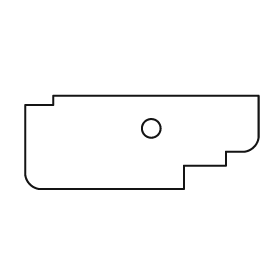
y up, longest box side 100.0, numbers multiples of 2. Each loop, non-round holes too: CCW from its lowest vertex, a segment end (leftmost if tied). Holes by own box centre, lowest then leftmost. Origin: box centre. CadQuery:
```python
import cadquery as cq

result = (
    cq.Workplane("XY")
    .moveTo(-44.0, -20.0)
    .lineTo(18.0, -20.0)
    .lineTo(18.0, -10.0)
    .lineTo(36.0, -10.0)
    .lineTo(36.0, -4.0)
    .lineTo(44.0, -4.0)
    .threePointArc((48.0, -2.0), (50.0, 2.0))
    .lineTo(50.0, 20.0)
    .lineTo(-38.0, 20.0)
    .lineTo(-38.0, 16.0)
    .lineTo(-50.0, 16.0)
    .lineTo(-50.0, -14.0)
    .threePointArc((-48.0, -18.0), (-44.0, -20.0))
    .close()
    .moveTo(4.0, 6.0)
    .circle(4.0)
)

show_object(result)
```